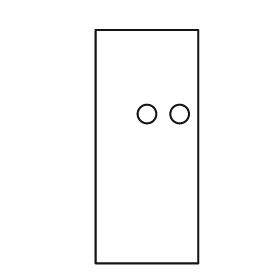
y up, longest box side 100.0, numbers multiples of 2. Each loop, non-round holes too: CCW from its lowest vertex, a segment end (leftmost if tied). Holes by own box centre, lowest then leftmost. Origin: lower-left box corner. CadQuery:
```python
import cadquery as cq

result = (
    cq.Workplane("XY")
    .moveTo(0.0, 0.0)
    .lineTo(44.0, 0.0)
    .lineTo(44.0, 100.0)
    .lineTo(0.0, 100.0)
    .close()
    .moveTo(22.0, 64.0)
    .circle(4.0)
    .moveTo(36.0, 64.0)
    .circle(4.0)
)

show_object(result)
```